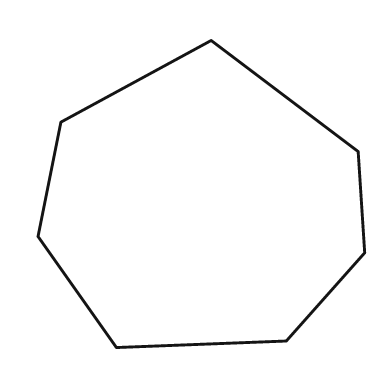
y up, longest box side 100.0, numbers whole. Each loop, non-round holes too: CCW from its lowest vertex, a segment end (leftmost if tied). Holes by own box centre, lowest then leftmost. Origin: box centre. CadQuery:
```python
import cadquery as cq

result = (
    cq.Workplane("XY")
    .moveTo(-26.0, -47.0)
    .lineTo(26.0, -45.0)
    .lineTo(50.0, -18.0)
    .lineTo(48.0, 13.0)
    .lineTo(3.0, 47.0)
    .lineTo(-43.0, 22.0)
    .lineTo(-50.0, -13.0)
    .close()
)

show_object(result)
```